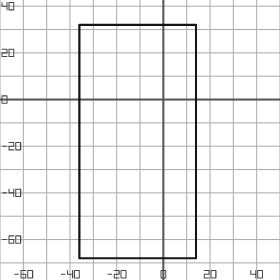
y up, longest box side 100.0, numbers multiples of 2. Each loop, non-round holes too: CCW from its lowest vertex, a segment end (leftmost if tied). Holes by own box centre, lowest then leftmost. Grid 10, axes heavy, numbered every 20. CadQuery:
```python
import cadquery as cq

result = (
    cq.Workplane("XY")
    .moveTo(-36.0, -68.0)
    .lineTo(14.0, -68.0)
    .lineTo(14.0, 32.0)
    .lineTo(-36.0, 32.0)
    .close()
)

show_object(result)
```